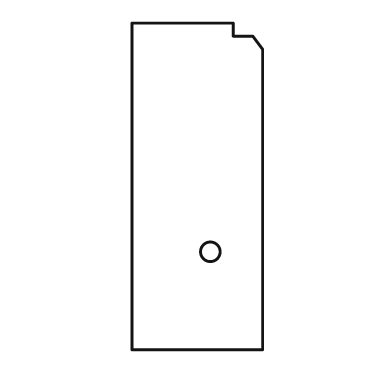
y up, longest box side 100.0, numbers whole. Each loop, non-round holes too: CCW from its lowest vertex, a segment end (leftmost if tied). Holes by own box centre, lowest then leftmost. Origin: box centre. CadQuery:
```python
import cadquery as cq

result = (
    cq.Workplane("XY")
    .moveTo(-20.0, -50.0)
    .lineTo(20.0, -50.0)
    .lineTo(20.0, 42.0)
    .lineTo(17.0, 46.0)
    .lineTo(11.0, 46.0)
    .lineTo(11.0, 50.0)
    .lineTo(-20.0, 50.0)
    .close()
    .moveTo(4.0, -20.0)
    .circle(3.0)
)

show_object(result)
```